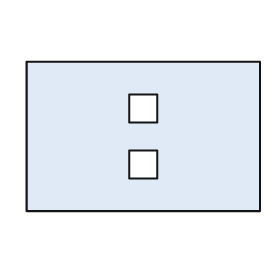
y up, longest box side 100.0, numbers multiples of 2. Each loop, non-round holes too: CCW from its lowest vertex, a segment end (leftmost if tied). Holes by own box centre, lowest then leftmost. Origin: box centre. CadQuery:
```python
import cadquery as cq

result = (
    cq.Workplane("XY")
    .moveTo(-50.0, -32.0)
    .lineTo(50.0, -32.0)
    .lineTo(50.0, 32.0)
    .lineTo(-50.0, 32.0)
    .close()
    .moveTo(-6.0, -18.0)
    .lineTo(6.0, -18.0)
    .lineTo(6.0, -6.0)
    .lineTo(-6.0, -6.0)
    .close()
    .moveTo(-6.0, 6.0)
    .lineTo(6.0, 6.0)
    .lineTo(6.0, 18.0)
    .lineTo(-6.0, 18.0)
    .close()
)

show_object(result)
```